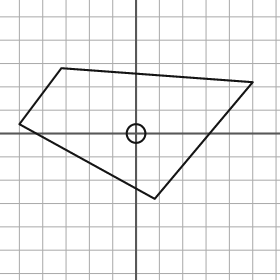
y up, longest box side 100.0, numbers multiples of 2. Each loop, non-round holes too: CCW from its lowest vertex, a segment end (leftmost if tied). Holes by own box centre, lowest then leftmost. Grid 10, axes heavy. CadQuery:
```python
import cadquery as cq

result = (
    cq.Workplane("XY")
    .moveTo(8.0, -28.0)
    .lineTo(50.0, 22.0)
    .lineTo(-32.0, 28.0)
    .lineTo(-50.0, 4.0)
    .close()
    .moveTo(0.0, 0.0)
    .circle(4.0)
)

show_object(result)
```